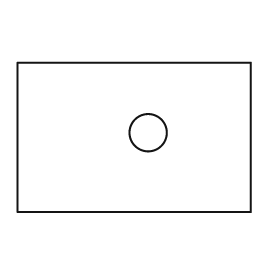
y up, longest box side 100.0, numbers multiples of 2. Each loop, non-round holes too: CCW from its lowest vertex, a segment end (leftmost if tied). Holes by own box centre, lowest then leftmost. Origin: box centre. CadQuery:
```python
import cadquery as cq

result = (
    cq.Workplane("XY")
    .moveTo(-50.0, -32.0)
    .lineTo(50.0, -32.0)
    .lineTo(50.0, 32.0)
    .lineTo(-50.0, 32.0)
    .close()
    .moveTo(6.0, 2.0)
    .circle(8.0)
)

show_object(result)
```